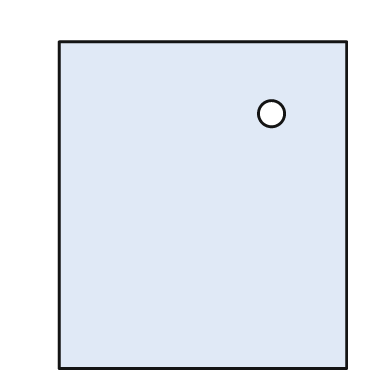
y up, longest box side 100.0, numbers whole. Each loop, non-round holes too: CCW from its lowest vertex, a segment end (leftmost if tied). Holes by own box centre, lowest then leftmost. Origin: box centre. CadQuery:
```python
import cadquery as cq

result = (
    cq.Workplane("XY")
    .moveTo(-44.0, -50.0)
    .lineTo(44.0, -50.0)
    .lineTo(44.0, 50.0)
    .lineTo(-44.0, 50.0)
    .close()
    .moveTo(21.0, 28.0)
    .circle(4.0)
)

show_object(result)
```